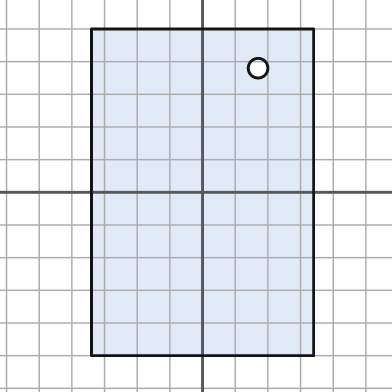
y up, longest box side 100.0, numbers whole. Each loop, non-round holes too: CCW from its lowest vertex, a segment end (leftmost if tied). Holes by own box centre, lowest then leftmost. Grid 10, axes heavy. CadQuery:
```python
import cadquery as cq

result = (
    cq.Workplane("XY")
    .moveTo(-34.0, -50.0)
    .lineTo(34.0, -50.0)
    .lineTo(34.0, 50.0)
    .lineTo(-34.0, 50.0)
    .close()
    .moveTo(17.0, 38.0)
    .circle(3.0)
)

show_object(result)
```